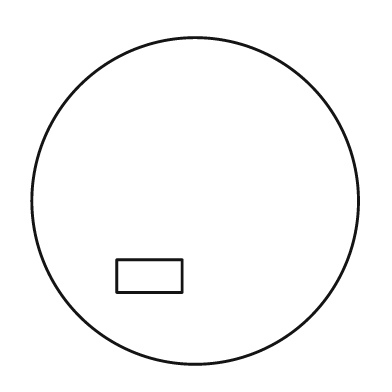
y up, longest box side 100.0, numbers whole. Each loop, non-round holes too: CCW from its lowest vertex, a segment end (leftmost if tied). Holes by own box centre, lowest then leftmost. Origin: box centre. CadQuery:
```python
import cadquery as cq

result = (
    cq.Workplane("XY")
    .moveTo(0.0, 0.0)
    .circle(50.0)
    .moveTo(-24.0, -28.0)
    .lineTo(-4.0, -28.0)
    .lineTo(-4.0, -18.0)
    .lineTo(-24.0, -18.0)
    .close()
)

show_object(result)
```